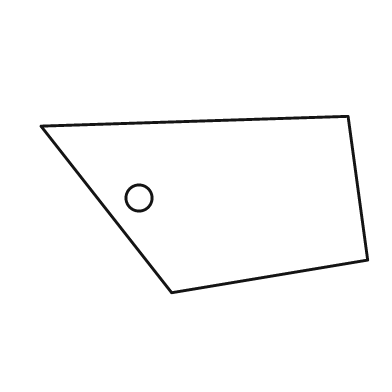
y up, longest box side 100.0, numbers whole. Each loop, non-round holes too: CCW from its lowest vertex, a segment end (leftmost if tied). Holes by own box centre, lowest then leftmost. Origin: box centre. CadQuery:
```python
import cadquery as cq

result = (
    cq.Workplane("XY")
    .moveTo(-10.0, -27.0)
    .lineTo(50.0, -17.0)
    .lineTo(44.0, 27.0)
    .lineTo(-50.0, 24.0)
    .close()
    .moveTo(-20.0, 2.0)
    .circle(4.0)
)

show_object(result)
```